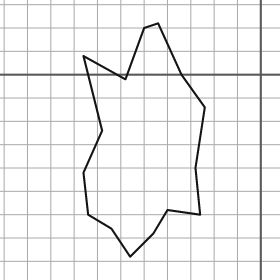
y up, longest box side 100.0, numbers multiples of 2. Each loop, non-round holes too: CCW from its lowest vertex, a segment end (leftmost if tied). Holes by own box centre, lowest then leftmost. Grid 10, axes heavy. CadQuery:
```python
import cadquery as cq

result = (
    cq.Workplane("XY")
    .moveTo(-56.0, -78.0)
    .lineTo(-46.0, -68.0)
    .lineTo(-40.0, -58.0)
    .lineTo(-26.0, -60.0)
    .lineTo(-28.0, -40.0)
    .lineTo(-24.0, -14.0)
    .lineTo(-34.0, 0.0)
    .lineTo(-44.0, 22.0)
    .lineTo(-50.0, 20.0)
    .lineTo(-58.0, -2.0)
    .lineTo(-76.0, 8.0)
    .lineTo(-68.0, -24.0)
    .lineTo(-76.0, -42.0)
    .lineTo(-74.0, -60.0)
    .lineTo(-64.0, -66.0)
    .close()
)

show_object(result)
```